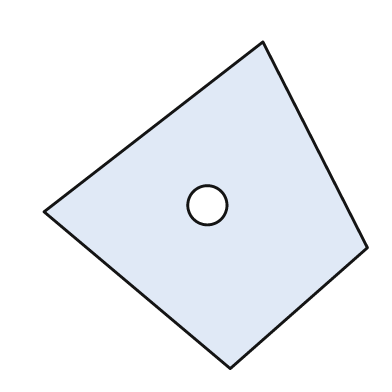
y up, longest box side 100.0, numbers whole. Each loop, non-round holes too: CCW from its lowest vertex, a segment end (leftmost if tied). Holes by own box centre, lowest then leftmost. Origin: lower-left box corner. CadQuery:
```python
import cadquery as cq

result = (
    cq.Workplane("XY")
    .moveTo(57.0, 0.0)
    .lineTo(99.0, 37.0)
    .lineTo(67.0, 100.0)
    .lineTo(0.0, 48.0)
    .close()
    .moveTo(50.0, 50.0)
    .circle(6.0)
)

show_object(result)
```